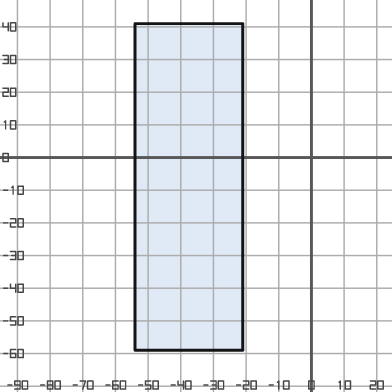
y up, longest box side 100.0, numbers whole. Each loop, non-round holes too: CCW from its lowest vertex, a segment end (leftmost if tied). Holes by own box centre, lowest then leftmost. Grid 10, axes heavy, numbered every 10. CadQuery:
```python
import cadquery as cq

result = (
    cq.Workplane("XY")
    .moveTo(-54.0, -59.0)
    .lineTo(-21.0, -59.0)
    .lineTo(-21.0, 41.0)
    .lineTo(-54.0, 41.0)
    .close()
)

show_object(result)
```